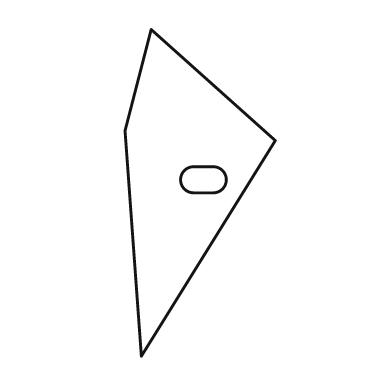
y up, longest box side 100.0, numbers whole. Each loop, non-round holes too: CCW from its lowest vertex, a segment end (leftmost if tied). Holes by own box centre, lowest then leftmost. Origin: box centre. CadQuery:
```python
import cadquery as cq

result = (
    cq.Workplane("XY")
    .moveTo(-18.0, -50.0)
    .lineTo(23.0, 16.0)
    .lineTo(-15.0, 50.0)
    .lineTo(-23.0, 19.0)
    .close()
    .moveTo(-2.0, 0.0)
    .lineTo(4.0, 0.0)
    .threePointArc((8.0, 4.0), (4.0, 8.0))
    .lineTo(-2.0, 8.0)
    .threePointArc((-6.0, 4.0), (-2.0, 0.0))
    .close()
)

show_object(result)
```